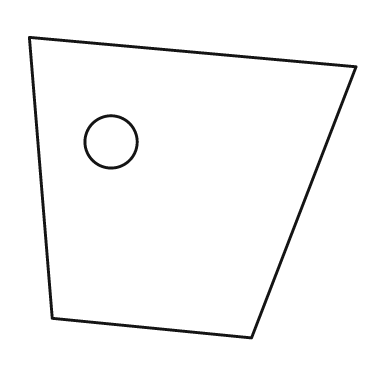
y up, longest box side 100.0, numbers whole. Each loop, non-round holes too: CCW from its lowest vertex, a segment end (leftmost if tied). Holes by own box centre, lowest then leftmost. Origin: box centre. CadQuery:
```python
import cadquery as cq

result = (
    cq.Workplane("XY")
    .moveTo(18.0, -46.0)
    .lineTo(50.0, 37.0)
    .lineTo(-50.0, 46.0)
    .lineTo(-43.0, -40.0)
    .close()
    .moveTo(-25.0, 14.0)
    .circle(8.0)
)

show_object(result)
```